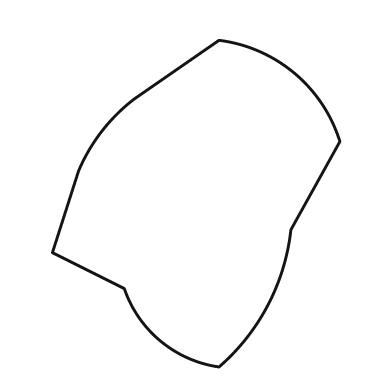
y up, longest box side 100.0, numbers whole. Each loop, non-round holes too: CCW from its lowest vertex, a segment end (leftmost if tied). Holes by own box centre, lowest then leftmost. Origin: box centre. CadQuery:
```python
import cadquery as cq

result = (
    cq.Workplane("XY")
    .moveTo(7.0, -50.0)
    .threePointArc((22.0, -31.0), (29.0, -8.0))
    .lineTo(44.0, 19.0)
    .threePointArc((30.0, 40.0), (7.0, 50.0))
    .lineTo(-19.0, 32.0)
    .threePointArc((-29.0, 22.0), (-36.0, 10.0))
    .lineTo(-44.0, -15.0)
    .lineTo(-22.0, -26.0)
    .threePointArc((-11.0, -42.0), (7.0, -50.0))
    .close()
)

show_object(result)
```